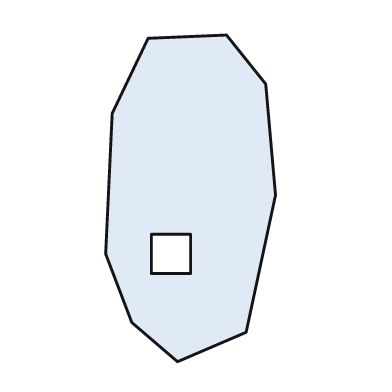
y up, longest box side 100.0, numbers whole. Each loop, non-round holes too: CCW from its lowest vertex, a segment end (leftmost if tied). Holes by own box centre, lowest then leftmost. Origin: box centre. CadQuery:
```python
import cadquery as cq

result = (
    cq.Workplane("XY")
    .moveTo(-4.0, -50.0)
    .lineTo(17.0, -41.0)
    .lineTo(26.0, 1.0)
    .lineTo(23.0, 35.0)
    .lineTo(11.0, 50.0)
    .lineTo(-13.0, 49.0)
    .lineTo(-24.0, 26.0)
    .lineTo(-26.0, -17.0)
    .lineTo(-18.0, -38.0)
    .close()
    .moveTo(-12.0, -23.0)
    .lineTo(0.0, -23.0)
    .lineTo(0.0, -11.0)
    .lineTo(-12.0, -11.0)
    .close()
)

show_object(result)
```